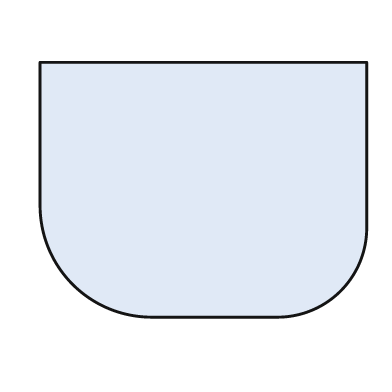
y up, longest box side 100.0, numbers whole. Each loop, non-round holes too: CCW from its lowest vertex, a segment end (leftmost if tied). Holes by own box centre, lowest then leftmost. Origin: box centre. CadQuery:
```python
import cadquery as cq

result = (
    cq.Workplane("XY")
    .moveTo(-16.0, -39.0)
    .lineTo(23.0, -39.0)
    .threePointArc((42.0, -31.0), (50.0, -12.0))
    .lineTo(50.0, 39.0)
    .lineTo(-50.0, 39.0)
    .lineTo(-50.0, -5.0)
    .threePointArc((-40.0, -29.0), (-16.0, -39.0))
    .close()
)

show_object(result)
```